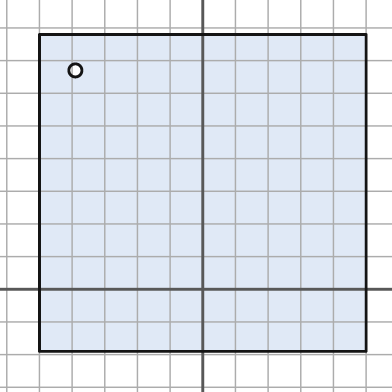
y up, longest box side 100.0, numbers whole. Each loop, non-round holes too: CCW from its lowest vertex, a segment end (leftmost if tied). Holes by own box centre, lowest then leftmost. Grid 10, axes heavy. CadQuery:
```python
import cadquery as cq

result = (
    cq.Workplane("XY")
    .moveTo(-50.0, -19.0)
    .lineTo(50.0, -19.0)
    .lineTo(50.0, 78.0)
    .lineTo(-50.0, 78.0)
    .close()
    .moveTo(-39.0, 67.0)
    .circle(2.0)
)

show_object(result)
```